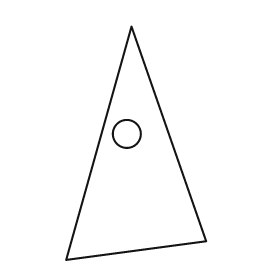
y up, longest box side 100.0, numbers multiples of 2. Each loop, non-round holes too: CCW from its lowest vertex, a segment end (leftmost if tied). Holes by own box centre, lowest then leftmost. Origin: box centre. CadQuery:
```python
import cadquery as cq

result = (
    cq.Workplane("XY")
    .moveTo(-30.0, -50.0)
    .lineTo(30.0, -42.0)
    .lineTo(-2.0, 50.0)
    .close()
    .moveTo(-4.0, 4.0)
    .circle(6.0)
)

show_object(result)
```